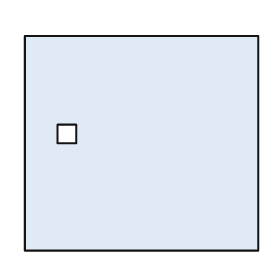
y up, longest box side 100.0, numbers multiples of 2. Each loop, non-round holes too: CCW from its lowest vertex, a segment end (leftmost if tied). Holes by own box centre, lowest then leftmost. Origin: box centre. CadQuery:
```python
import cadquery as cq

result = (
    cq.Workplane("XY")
    .moveTo(-50.0, -46.0)
    .lineTo(50.0, -46.0)
    .lineTo(50.0, 46.0)
    .lineTo(-50.0, 46.0)
    .close()
    .moveTo(-36.0, 0.0)
    .lineTo(-28.0, 0.0)
    .lineTo(-28.0, 8.0)
    .lineTo(-36.0, 8.0)
    .close()
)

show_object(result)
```